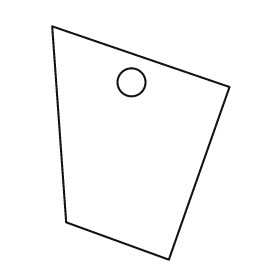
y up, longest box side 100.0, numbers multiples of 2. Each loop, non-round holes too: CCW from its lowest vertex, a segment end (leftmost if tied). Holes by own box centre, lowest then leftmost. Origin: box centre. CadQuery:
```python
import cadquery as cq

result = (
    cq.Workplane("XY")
    .moveTo(12.0, -50.0)
    .lineTo(38.0, 24.0)
    .lineTo(-38.0, 50.0)
    .lineTo(-32.0, -34.0)
    .close()
    .moveTo(-4.0, 26.0)
    .circle(6.0)
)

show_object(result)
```